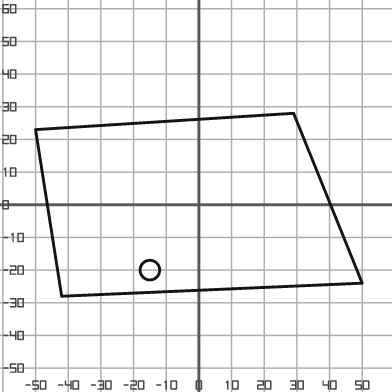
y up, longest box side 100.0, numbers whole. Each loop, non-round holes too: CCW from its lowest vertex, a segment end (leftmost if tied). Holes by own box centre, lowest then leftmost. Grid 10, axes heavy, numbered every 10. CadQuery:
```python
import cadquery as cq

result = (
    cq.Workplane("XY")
    .moveTo(-42.0, -28.0)
    .lineTo(50.0, -24.0)
    .lineTo(29.0, 28.0)
    .lineTo(-50.0, 23.0)
    .close()
    .moveTo(-15.0, -20.0)
    .circle(3.0)
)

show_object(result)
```